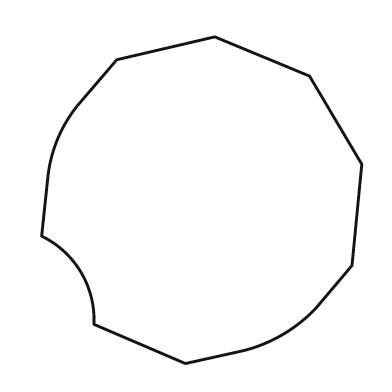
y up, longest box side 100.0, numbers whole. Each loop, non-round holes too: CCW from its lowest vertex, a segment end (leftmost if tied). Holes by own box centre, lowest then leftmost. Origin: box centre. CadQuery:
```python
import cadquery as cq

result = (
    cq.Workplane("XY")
    .moveTo(-5.0, -50.0)
    .lineTo(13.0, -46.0)
    .threePointArc((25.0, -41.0), (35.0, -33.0))
    .lineTo(46.0, -20.0)
    .lineTo(49.0, 11.0)
    .lineTo(33.0, 38.0)
    .lineTo(4.0, 50.0)
    .lineTo(-26.0, 43.0)
    .lineTo(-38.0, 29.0)
    .threePointArc((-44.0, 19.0), (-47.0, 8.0))
    .lineTo(-49.0, -11.0)
    .threePointArc((-37.0, -22.0), (-33.0, -38.0))
    .close()
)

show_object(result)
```